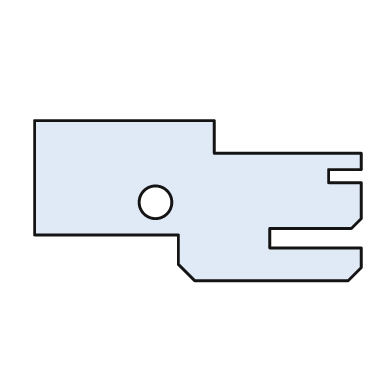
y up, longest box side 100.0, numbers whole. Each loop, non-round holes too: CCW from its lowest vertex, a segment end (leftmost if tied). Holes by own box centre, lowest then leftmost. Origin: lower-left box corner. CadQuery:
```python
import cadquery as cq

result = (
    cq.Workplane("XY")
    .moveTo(49.0, 0.0)
    .lineTo(96.0, 0.0)
    .lineTo(100.0, 4.0)
    .lineTo(100.0, 10.0)
    .lineTo(72.0, 10.0)
    .lineTo(72.0, 16.0)
    .lineTo(97.0, 16.0)
    .lineTo(100.0, 19.0)
    .lineTo(100.0, 30.0)
    .lineTo(90.0, 30.0)
    .lineTo(90.0, 34.0)
    .lineTo(100.0, 34.0)
    .lineTo(100.0, 39.0)
    .lineTo(55.0, 39.0)
    .lineTo(55.0, 49.0)
    .lineTo(0.0, 49.0)
    .lineTo(0.0, 14.0)
    .lineTo(44.0, 14.0)
    .lineTo(44.0, 5.0)
    .close()
    .moveTo(37.0, 24.0)
    .circle(5.0)
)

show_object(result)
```